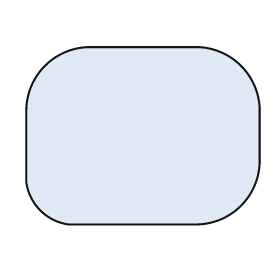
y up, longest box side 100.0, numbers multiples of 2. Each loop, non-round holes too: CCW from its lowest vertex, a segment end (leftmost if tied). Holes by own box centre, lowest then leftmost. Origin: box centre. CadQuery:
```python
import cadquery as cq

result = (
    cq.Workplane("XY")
    .moveTo(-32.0, -38.0)
    .lineTo(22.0, -38.0)
    .threePointArc((42.0, -30.0), (50.0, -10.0))
    .lineTo(50.0, 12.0)
    .threePointArc((42.0, 30.0), (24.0, 38.0))
    .lineTo(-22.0, 38.0)
    .threePointArc((-42.0, 30.0), (-50.0, 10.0))
    .lineTo(-50.0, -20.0)
    .threePointArc((-44.0, -32.0), (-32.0, -38.0))
    .close()
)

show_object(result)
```